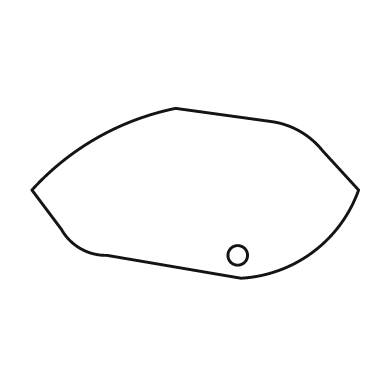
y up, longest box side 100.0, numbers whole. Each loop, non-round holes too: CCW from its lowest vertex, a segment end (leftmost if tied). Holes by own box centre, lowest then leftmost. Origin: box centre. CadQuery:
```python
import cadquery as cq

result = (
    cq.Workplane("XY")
    .moveTo(14.0, -26.0)
    .threePointArc((36.0, -18.0), (50.0, 1.0))
    .lineTo(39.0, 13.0)
    .threePointArc((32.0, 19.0), (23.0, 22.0))
    .lineTo(-6.0, 26.0)
    .threePointArc((-30.0, 17.0), (-50.0, 1.0))
    .lineTo(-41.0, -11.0)
    .threePointArc((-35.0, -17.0), (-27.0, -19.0))
    .close()
    .moveTo(13.0, -19.0)
    .circle(3.0)
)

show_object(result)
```